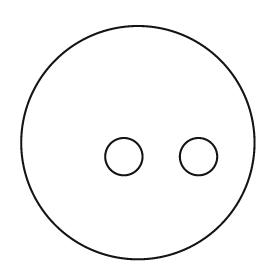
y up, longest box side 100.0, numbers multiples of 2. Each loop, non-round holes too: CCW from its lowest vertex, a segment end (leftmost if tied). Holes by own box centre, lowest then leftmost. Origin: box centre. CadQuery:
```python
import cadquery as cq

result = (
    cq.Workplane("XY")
    .moveTo(0.0, 0.0)
    .circle(50.0)
    .moveTo(-6.0, -6.0)
    .circle(8.0)
    .moveTo(26.0, -6.0)
    .circle(8.0)
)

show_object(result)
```